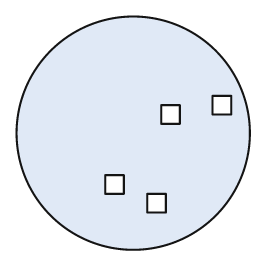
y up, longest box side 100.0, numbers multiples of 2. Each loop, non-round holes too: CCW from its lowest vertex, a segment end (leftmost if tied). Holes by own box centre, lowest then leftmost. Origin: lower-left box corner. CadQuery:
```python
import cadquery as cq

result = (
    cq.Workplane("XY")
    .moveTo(50.0, 50.0)
    .circle(50.0)
    .moveTo(56.0, 16.0)
    .lineTo(64.0, 16.0)
    .lineTo(64.0, 24.0)
    .lineTo(56.0, 24.0)
    .close()
    .moveTo(38.0, 24.0)
    .lineTo(46.0, 24.0)
    .lineTo(46.0, 32.0)
    .lineTo(38.0, 32.0)
    .close()
    .moveTo(62.0, 54.0)
    .lineTo(70.0, 54.0)
    .lineTo(70.0, 62.0)
    .lineTo(62.0, 62.0)
    .close()
    .moveTo(84.0, 58.0)
    .lineTo(92.0, 58.0)
    .lineTo(92.0, 66.0)
    .lineTo(84.0, 66.0)
    .close()
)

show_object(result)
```